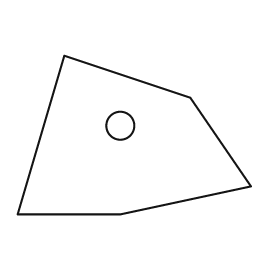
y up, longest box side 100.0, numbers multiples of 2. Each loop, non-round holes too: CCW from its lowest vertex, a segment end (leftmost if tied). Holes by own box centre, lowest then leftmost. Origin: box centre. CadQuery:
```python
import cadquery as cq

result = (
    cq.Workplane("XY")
    .moveTo(-50.0, -34.0)
    .lineTo(-6.0, -34.0)
    .lineTo(50.0, -22.0)
    .lineTo(24.0, 16.0)
    .lineTo(-30.0, 34.0)
    .close()
    .moveTo(-6.0, 4.0)
    .circle(6.0)
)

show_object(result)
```